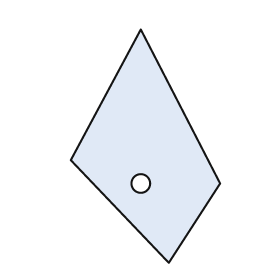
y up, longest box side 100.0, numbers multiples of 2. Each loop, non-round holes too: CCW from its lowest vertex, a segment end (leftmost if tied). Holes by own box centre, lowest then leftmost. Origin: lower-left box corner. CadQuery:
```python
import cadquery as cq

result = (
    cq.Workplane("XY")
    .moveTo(42.0, 0.0)
    .lineTo(64.0, 34.0)
    .lineTo(30.0, 100.0)
    .lineTo(0.0, 44.0)
    .close()
    .moveTo(30.0, 34.0)
    .circle(4.0)
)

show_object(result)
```